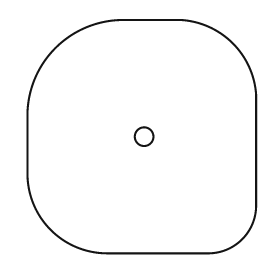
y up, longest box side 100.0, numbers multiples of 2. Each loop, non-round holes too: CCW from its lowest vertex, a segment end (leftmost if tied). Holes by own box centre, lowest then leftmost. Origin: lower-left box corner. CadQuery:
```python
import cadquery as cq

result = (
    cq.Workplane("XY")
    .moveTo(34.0, 0.0)
    .lineTo(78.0, 0.0)
    .threePointArc((92.0, 6.0), (98.0, 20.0))
    .lineTo(98.0, 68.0)
    .threePointArc((88.0, 90.0), (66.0, 100.0))
    .lineTo(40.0, 100.0)
    .threePointArc((12.0, 88.0), (0.0, 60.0))
    .lineTo(0.0, 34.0)
    .threePointArc((10.0, 10.0), (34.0, 0.0))
    .close()
    .moveTo(50.0, 50.0)
    .circle(4.0)
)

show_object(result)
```